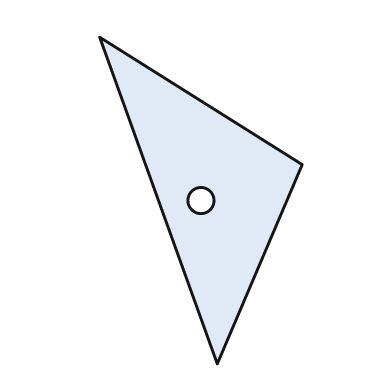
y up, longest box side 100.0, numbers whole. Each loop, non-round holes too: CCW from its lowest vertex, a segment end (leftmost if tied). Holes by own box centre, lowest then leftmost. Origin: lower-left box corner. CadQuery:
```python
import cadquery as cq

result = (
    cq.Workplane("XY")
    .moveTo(36.0, 0.0)
    .lineTo(62.0, 61.0)
    .lineTo(0.0, 100.0)
    .close()
    .moveTo(31.0, 50.0)
    .circle(4.0)
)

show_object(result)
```